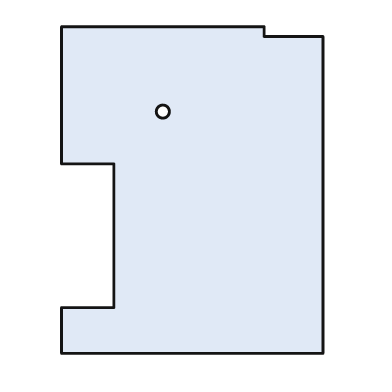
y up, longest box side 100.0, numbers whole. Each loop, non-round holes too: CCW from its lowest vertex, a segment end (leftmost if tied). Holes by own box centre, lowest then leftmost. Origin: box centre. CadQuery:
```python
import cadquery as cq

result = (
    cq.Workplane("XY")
    .moveTo(-40.0, -50.0)
    .lineTo(40.0, -50.0)
    .lineTo(40.0, 47.0)
    .lineTo(22.0, 47.0)
    .lineTo(22.0, 50.0)
    .lineTo(-40.0, 50.0)
    .lineTo(-40.0, 8.0)
    .lineTo(-24.0, 8.0)
    .lineTo(-24.0, -36.0)
    .lineTo(-40.0, -36.0)
    .close()
    .moveTo(-9.0, 24.0)
    .circle(2.0)
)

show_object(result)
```